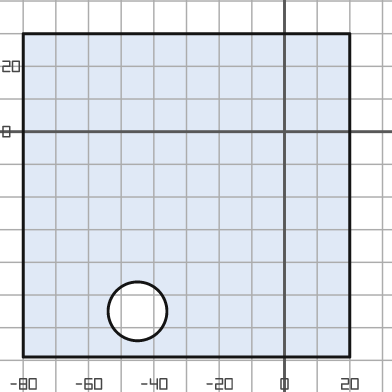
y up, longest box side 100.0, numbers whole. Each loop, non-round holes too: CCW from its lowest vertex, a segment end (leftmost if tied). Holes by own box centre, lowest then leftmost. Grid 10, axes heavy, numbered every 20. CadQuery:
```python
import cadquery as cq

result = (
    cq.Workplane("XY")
    .moveTo(-80.0, -69.0)
    .lineTo(20.0, -69.0)
    .lineTo(20.0, 30.0)
    .lineTo(-80.0, 30.0)
    .close()
    .moveTo(-45.0, -55.0)
    .circle(9.0)
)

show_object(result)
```